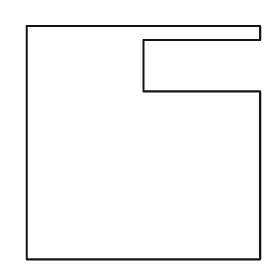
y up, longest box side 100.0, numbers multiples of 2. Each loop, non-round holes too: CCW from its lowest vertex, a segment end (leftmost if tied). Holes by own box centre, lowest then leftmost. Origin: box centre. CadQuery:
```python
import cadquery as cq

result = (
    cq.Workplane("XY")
    .moveTo(-50.0, -50.0)
    .lineTo(50.0, -50.0)
    .lineTo(50.0, 22.0)
    .lineTo(0.0, 22.0)
    .lineTo(0.0, 44.0)
    .lineTo(50.0, 44.0)
    .lineTo(50.0, 50.0)
    .lineTo(-50.0, 50.0)
    .close()
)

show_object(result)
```